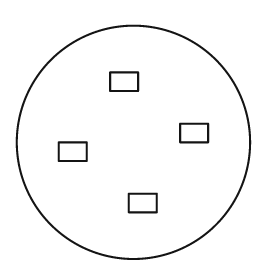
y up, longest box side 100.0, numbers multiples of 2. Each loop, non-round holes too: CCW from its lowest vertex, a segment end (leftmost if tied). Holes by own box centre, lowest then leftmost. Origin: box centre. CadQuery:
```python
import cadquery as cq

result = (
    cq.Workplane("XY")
    .moveTo(0.0, 0.0)
    .circle(50.0)
    .moveTo(-2.0, -30.0)
    .lineTo(10.0, -30.0)
    .lineTo(10.0, -22.0)
    .lineTo(-2.0, -22.0)
    .close()
    .moveTo(-32.0, -8.0)
    .lineTo(-20.0, -8.0)
    .lineTo(-20.0, 0.0)
    .lineTo(-32.0, 0.0)
    .close()
    .moveTo(20.0, 0.0)
    .lineTo(32.0, 0.0)
    .lineTo(32.0, 8.0)
    .lineTo(20.0, 8.0)
    .close()
    .moveTo(-10.0, 22.0)
    .lineTo(2.0, 22.0)
    .lineTo(2.0, 30.0)
    .lineTo(-10.0, 30.0)
    .close()
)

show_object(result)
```